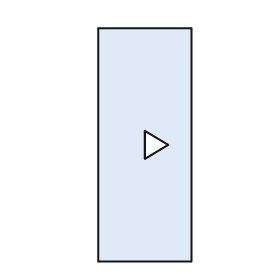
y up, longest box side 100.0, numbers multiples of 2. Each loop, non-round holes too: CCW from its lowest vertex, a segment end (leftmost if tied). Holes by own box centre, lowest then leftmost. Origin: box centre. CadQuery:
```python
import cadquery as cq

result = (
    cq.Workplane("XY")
    .moveTo(-20.0, -50.0)
    .lineTo(20.0, -50.0)
    .lineTo(20.0, 50.0)
    .lineTo(-20.0, 50.0)
    .close()
    .moveTo(0.0, -6.0)
    .lineTo(10.0, 0.0)
    .lineTo(0.0, 6.0)
    .close()
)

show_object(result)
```